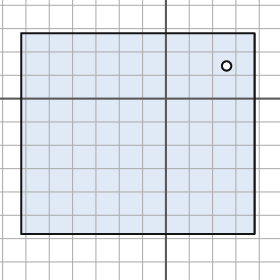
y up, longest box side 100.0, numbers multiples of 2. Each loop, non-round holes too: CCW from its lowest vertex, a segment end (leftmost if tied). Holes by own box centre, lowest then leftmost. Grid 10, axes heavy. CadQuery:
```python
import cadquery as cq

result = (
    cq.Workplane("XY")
    .moveTo(-62.0, -58.0)
    .lineTo(38.0, -58.0)
    .lineTo(38.0, 28.0)
    .lineTo(-62.0, 28.0)
    .close()
    .moveTo(26.0, 14.0)
    .circle(2.0)
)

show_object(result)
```